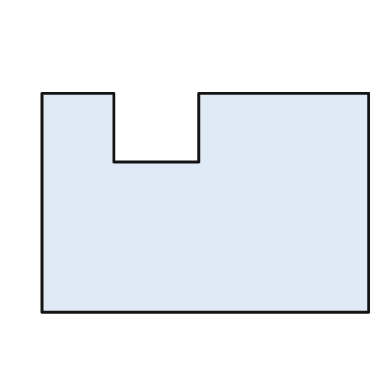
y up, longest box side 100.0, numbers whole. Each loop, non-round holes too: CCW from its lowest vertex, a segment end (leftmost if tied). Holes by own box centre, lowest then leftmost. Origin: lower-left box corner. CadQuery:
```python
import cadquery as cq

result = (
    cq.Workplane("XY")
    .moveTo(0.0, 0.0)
    .lineTo(100.0, 0.0)
    .lineTo(100.0, 67.0)
    .lineTo(48.0, 67.0)
    .lineTo(48.0, 46.0)
    .lineTo(22.0, 46.0)
    .lineTo(22.0, 67.0)
    .lineTo(0.0, 67.0)
    .close()
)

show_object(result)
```